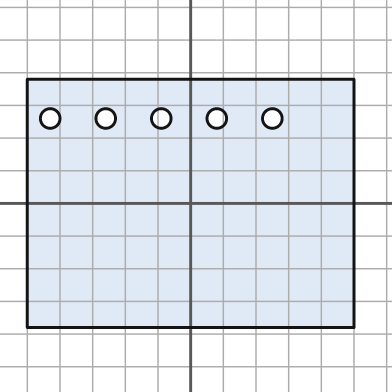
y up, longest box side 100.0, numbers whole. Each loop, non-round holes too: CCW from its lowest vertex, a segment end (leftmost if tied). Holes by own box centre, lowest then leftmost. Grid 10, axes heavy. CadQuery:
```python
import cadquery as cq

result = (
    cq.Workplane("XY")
    .moveTo(-50.0, -38.0)
    .lineTo(50.0, -38.0)
    .lineTo(50.0, 38.0)
    .lineTo(-50.0, 38.0)
    .close()
    .moveTo(-43.0, 26.0)
    .circle(3.0)
    .moveTo(-26.0, 26.0)
    .circle(3.0)
    .moveTo(-9.0, 26.0)
    .circle(3.0)
    .moveTo(8.0, 26.0)
    .circle(3.0)
    .moveTo(25.0, 26.0)
    .circle(3.0)
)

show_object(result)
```